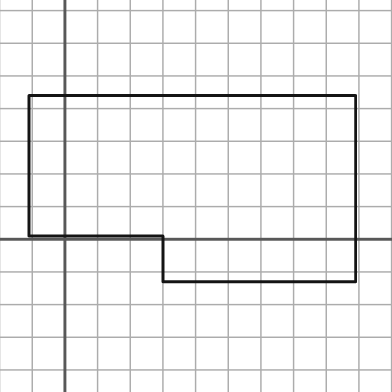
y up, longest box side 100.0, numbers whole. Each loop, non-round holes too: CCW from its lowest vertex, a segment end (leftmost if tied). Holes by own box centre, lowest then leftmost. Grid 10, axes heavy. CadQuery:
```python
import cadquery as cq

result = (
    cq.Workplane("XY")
    .moveTo(30.0, -13.0)
    .lineTo(89.0, -13.0)
    .lineTo(89.0, 44.0)
    .lineTo(-11.0, 44.0)
    .lineTo(-11.0, 1.0)
    .lineTo(30.0, 1.0)
    .close()
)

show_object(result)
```